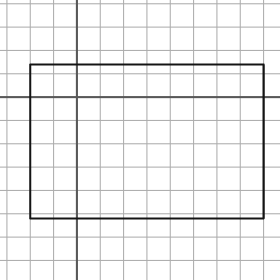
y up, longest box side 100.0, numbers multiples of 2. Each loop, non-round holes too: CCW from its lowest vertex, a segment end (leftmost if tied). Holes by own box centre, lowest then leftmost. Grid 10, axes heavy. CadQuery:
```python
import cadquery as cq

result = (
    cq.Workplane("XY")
    .moveTo(-20.0, -52.0)
    .lineTo(80.0, -52.0)
    .lineTo(80.0, 14.0)
    .lineTo(-20.0, 14.0)
    .close()
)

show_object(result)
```